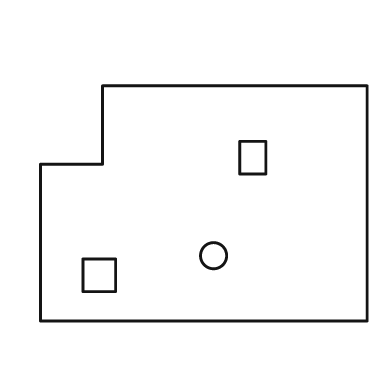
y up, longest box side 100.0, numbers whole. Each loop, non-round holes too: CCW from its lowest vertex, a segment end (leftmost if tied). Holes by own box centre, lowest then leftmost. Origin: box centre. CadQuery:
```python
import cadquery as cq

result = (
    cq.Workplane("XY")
    .moveTo(-50.0, -36.0)
    .lineTo(50.0, -36.0)
    .lineTo(50.0, 36.0)
    .lineTo(-31.0, 36.0)
    .lineTo(-31.0, 12.0)
    .lineTo(-50.0, 12.0)
    .close()
    .moveTo(-37.0, -27.0)
    .lineTo(-27.0, -27.0)
    .lineTo(-27.0, -17.0)
    .lineTo(-37.0, -17.0)
    .close()
    .moveTo(3.0, -16.0)
    .circle(4.0)
    .moveTo(11.0, 9.0)
    .lineTo(19.0, 9.0)
    .lineTo(19.0, 19.0)
    .lineTo(11.0, 19.0)
    .close()
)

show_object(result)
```